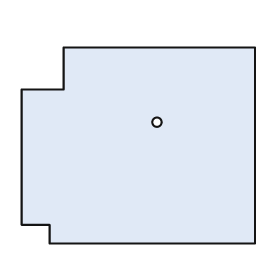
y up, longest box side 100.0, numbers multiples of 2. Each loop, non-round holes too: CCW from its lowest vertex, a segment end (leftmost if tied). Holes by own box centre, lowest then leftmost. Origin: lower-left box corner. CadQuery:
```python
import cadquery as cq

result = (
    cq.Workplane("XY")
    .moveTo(12.0, 0.0)
    .lineTo(100.0, 0.0)
    .lineTo(100.0, 84.0)
    .lineTo(18.0, 84.0)
    .lineTo(18.0, 66.0)
    .lineTo(0.0, 66.0)
    .lineTo(0.0, 8.0)
    .lineTo(12.0, 8.0)
    .close()
    .moveTo(58.0, 52.0)
    .circle(2.0)
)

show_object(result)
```